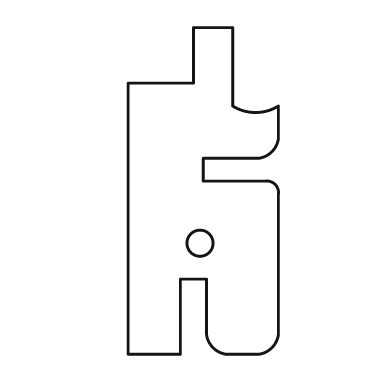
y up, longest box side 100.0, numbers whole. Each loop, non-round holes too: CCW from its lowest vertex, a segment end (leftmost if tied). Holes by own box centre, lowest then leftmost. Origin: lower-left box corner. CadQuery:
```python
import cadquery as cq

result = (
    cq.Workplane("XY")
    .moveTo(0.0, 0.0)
    .lineTo(16.0, 0.0)
    .lineTo(16.0, 23.0)
    .lineTo(24.0, 23.0)
    .lineTo(24.0, 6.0)
    .threePointArc((26.0, 2.0), (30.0, 0.0))
    .lineTo(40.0, 0.0)
    .threePointArc((44.0, 2.0), (46.0, 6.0))
    .lineTo(46.0, 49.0)
    .threePointArc((45.0, 52.0), (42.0, 53.0))
    .lineTo(23.0, 53.0)
    .lineTo(23.0, 60.0)
    .lineTo(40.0, 60.0)
    .threePointArc((44.0, 62.0), (46.0, 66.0))
    .lineTo(46.0, 76.0)
    .threePointArc((39.0, 74.0), (32.0, 76.0))
    .lineTo(32.0, 100.0)
    .lineTo(20.0, 100.0)
    .lineTo(20.0, 83.0)
    .lineTo(0.0, 83.0)
    .close()
    .moveTo(22.0, 34.0)
    .circle(4.0)
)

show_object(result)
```